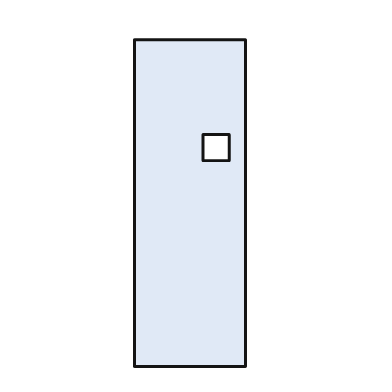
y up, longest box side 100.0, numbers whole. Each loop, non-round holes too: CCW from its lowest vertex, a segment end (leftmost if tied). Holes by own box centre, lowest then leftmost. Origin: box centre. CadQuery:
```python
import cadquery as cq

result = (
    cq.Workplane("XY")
    .moveTo(-17.0, -50.0)
    .lineTo(17.0, -50.0)
    .lineTo(17.0, 50.0)
    .lineTo(-17.0, 50.0)
    .close()
    .moveTo(4.0, 13.0)
    .lineTo(12.0, 13.0)
    .lineTo(12.0, 21.0)
    .lineTo(4.0, 21.0)
    .close()
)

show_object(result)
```